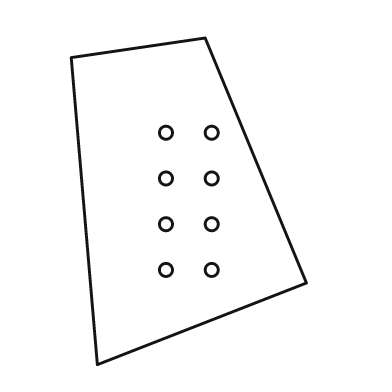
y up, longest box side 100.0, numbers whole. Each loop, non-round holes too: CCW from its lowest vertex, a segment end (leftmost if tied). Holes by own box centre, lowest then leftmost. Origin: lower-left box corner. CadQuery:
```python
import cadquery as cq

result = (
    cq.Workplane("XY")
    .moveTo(8.0, 0.0)
    .lineTo(72.0, 25.0)
    .lineTo(41.0, 100.0)
    .lineTo(0.0, 94.0)
    .close()
    .moveTo(29.0, 29.0)
    .circle(2.0)
    .moveTo(43.0, 29.0)
    .circle(2.0)
    .moveTo(29.0, 43.0)
    .circle(2.0)
    .moveTo(43.0, 43.0)
    .circle(2.0)
    .moveTo(29.0, 57.0)
    .circle(2.0)
    .moveTo(43.0, 57.0)
    .circle(2.0)
    .moveTo(29.0, 71.0)
    .circle(2.0)
    .moveTo(43.0, 71.0)
    .circle(2.0)
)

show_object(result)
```